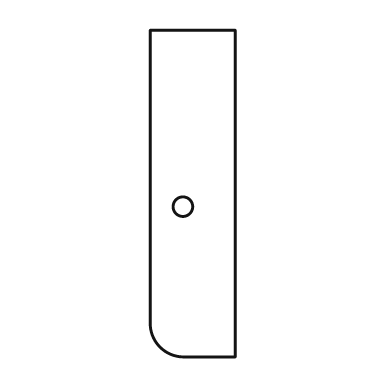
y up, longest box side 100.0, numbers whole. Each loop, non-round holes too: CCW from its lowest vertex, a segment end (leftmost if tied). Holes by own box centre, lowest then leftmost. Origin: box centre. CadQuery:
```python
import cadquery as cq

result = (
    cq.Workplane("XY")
    .moveTo(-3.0, -50.0)
    .lineTo(13.0, -50.0)
    .lineTo(13.0, 50.0)
    .lineTo(-13.0, 50.0)
    .lineTo(-13.0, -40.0)
    .threePointArc((-10.0, -47.0), (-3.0, -50.0))
    .close()
    .moveTo(-3.0, -4.0)
    .circle(3.0)
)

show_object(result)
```